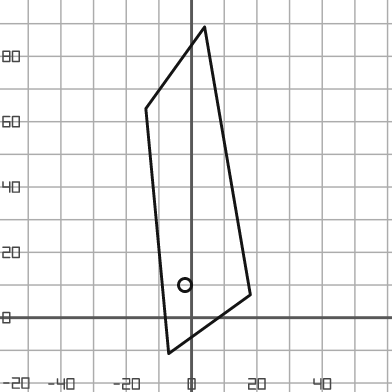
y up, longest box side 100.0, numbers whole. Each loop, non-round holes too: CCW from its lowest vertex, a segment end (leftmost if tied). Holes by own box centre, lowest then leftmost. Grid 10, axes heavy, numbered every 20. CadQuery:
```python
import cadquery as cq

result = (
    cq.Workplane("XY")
    .moveTo(-7.0, -11.0)
    .lineTo(18.0, 7.0)
    .lineTo(4.0, 89.0)
    .lineTo(-14.0, 64.0)
    .close()
    .moveTo(-2.0, 10.0)
    .circle(2.0)
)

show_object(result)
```